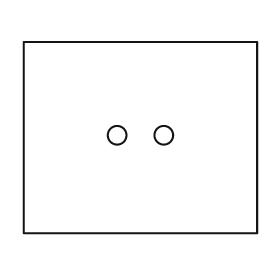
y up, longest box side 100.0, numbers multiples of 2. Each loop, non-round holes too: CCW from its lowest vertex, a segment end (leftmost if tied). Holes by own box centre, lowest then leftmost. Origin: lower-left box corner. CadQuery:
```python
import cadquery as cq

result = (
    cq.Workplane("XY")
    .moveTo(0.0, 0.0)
    .lineTo(100.0, 0.0)
    .lineTo(100.0, 82.0)
    .lineTo(0.0, 82.0)
    .close()
    .moveTo(40.0, 42.0)
    .circle(4.0)
    .moveTo(60.0, 42.0)
    .circle(4.0)
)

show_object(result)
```